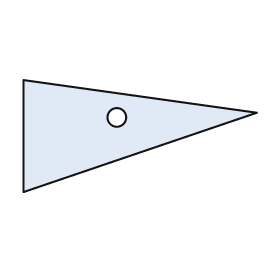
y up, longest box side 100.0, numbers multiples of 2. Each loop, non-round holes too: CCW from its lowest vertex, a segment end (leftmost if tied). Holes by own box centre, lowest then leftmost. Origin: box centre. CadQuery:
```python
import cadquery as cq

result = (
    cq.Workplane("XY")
    .moveTo(-50.0, -24.0)
    .lineTo(50.0, 10.0)
    .lineTo(-50.0, 24.0)
    .close()
    .moveTo(-10.0, 8.0)
    .circle(4.0)
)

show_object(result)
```